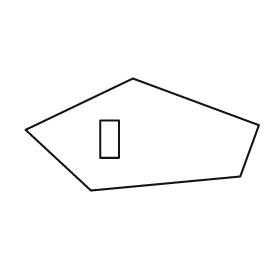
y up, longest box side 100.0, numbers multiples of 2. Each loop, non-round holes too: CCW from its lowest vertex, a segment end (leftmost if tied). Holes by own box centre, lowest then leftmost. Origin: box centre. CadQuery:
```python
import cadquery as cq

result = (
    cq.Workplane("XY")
    .moveTo(-22.0, -24.0)
    .lineTo(42.0, -18.0)
    .lineTo(50.0, 4.0)
    .lineTo(-4.0, 24.0)
    .lineTo(-50.0, 2.0)
    .close()
    .moveTo(-18.0, -10.0)
    .lineTo(-10.0, -10.0)
    .lineTo(-10.0, 6.0)
    .lineTo(-18.0, 6.0)
    .close()
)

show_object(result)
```